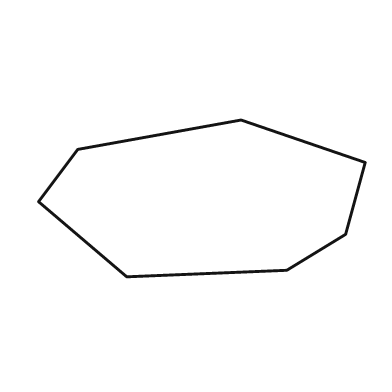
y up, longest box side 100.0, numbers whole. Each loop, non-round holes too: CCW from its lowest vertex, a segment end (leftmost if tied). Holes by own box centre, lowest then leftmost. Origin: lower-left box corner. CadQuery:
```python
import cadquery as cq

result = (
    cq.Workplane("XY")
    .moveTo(27.0, 0.0)
    .lineTo(76.0, 2.0)
    .lineTo(94.0, 13.0)
    .lineTo(100.0, 35.0)
    .lineTo(62.0, 48.0)
    .lineTo(12.0, 39.0)
    .lineTo(0.0, 23.0)
    .close()
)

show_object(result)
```